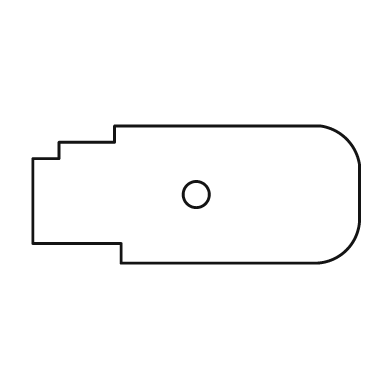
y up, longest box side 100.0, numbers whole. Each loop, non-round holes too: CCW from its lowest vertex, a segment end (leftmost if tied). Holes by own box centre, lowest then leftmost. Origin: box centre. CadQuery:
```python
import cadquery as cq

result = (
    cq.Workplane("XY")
    .moveTo(-23.0, -21.0)
    .lineTo(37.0, -21.0)
    .threePointArc((46.0, -17.0), (50.0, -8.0))
    .lineTo(50.0, 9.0)
    .threePointArc((46.0, 17.0), (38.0, 21.0))
    .lineTo(-25.0, 21.0)
    .lineTo(-25.0, 16.0)
    .lineTo(-42.0, 16.0)
    .lineTo(-42.0, 11.0)
    .lineTo(-50.0, 11.0)
    .lineTo(-50.0, -15.0)
    .lineTo(-23.0, -15.0)
    .close()
    .moveTo(0.0, 0.0)
    .circle(4.0)
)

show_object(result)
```